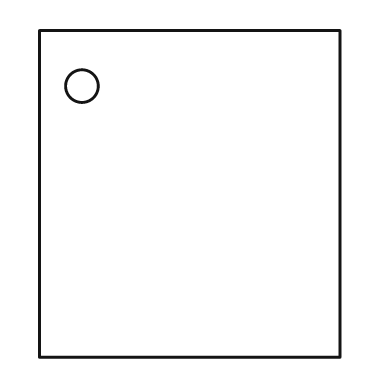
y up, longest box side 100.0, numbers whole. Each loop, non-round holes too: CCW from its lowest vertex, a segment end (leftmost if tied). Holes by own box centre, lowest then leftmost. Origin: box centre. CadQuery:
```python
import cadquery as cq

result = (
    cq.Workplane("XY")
    .moveTo(-46.0, -50.0)
    .lineTo(46.0, -50.0)
    .lineTo(46.0, 50.0)
    .lineTo(-46.0, 50.0)
    .close()
    .moveTo(-33.0, 33.0)
    .circle(5.0)
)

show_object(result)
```